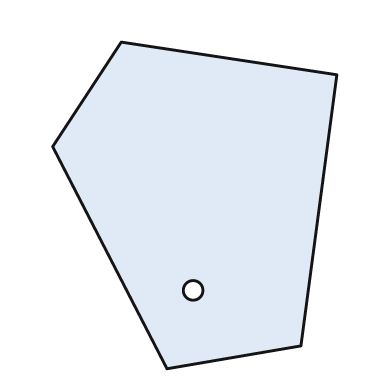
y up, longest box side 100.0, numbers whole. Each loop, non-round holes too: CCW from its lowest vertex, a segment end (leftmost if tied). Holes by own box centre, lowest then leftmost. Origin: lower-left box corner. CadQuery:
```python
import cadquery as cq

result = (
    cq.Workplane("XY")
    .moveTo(35.0, 0.0)
    .lineTo(76.0, 7.0)
    .lineTo(87.0, 90.0)
    .lineTo(21.0, 100.0)
    .lineTo(0.0, 68.0)
    .close()
    .moveTo(43.0, 24.0)
    .circle(3.0)
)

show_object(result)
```